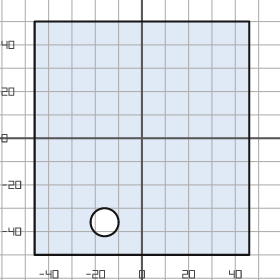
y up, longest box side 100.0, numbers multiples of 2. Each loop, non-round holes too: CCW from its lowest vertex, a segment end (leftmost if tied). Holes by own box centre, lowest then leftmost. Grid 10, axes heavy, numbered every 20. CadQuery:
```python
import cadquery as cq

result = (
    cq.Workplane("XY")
    .moveTo(-46.0, -50.0)
    .lineTo(46.0, -50.0)
    .lineTo(46.0, 50.0)
    .lineTo(-46.0, 50.0)
    .close()
    .moveTo(-16.0, -36.0)
    .circle(6.0)
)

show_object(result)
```